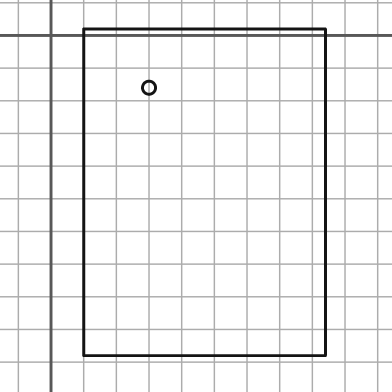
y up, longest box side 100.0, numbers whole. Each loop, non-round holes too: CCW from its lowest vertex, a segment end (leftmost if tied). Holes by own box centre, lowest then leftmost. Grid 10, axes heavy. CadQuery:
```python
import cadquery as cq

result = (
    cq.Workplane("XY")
    .moveTo(10.0, -98.0)
    .lineTo(84.0, -98.0)
    .lineTo(84.0, 2.0)
    .lineTo(10.0, 2.0)
    .close()
    .moveTo(30.0, -16.0)
    .circle(2.0)
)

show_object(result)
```